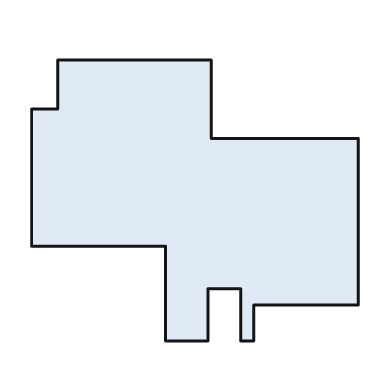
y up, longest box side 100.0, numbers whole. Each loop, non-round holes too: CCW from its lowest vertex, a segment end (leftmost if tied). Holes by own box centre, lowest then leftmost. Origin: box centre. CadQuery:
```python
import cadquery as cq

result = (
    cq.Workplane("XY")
    .moveTo(-9.0, -43.0)
    .lineTo(4.0, -43.0)
    .lineTo(4.0, -27.0)
    .lineTo(14.0, -27.0)
    .lineTo(14.0, -43.0)
    .lineTo(18.0, -43.0)
    .lineTo(18.0, -32.0)
    .lineTo(50.0, -32.0)
    .lineTo(50.0, 19.0)
    .lineTo(5.0, 19.0)
    .lineTo(5.0, 43.0)
    .lineTo(-42.0, 43.0)
    .lineTo(-42.0, 28.0)
    .lineTo(-50.0, 28.0)
    .lineTo(-50.0, -14.0)
    .lineTo(-9.0, -14.0)
    .close()
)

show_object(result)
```